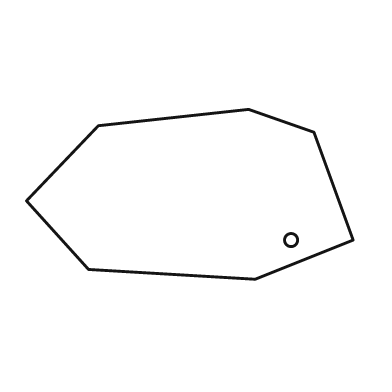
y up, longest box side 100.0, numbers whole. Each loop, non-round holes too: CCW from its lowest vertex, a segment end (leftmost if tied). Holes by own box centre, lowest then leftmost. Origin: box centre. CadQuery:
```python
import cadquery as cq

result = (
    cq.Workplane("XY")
    .moveTo(20.0, -26.0)
    .lineTo(50.0, -14.0)
    .lineTo(38.0, 19.0)
    .lineTo(18.0, 26.0)
    .lineTo(-28.0, 21.0)
    .lineTo(-50.0, -2.0)
    .lineTo(-31.0, -23.0)
    .close()
    .moveTo(31.0, -14.0)
    .circle(2.0)
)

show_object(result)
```